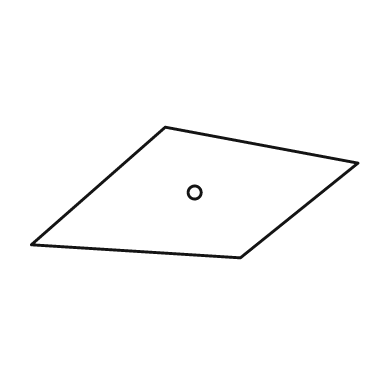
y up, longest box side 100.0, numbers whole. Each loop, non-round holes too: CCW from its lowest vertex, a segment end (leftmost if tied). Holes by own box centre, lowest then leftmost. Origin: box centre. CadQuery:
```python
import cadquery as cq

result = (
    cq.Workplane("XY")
    .moveTo(14.0, -20.0)
    .lineTo(50.0, 9.0)
    .lineTo(-9.0, 20.0)
    .lineTo(-50.0, -16.0)
    .close()
    .moveTo(0.0, 0.0)
    .circle(2.0)
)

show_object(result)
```